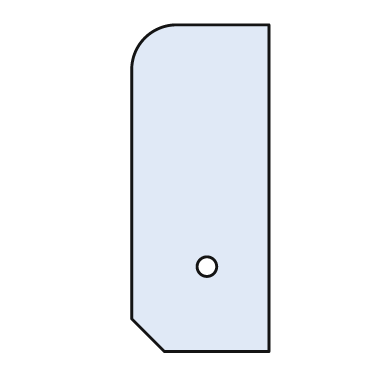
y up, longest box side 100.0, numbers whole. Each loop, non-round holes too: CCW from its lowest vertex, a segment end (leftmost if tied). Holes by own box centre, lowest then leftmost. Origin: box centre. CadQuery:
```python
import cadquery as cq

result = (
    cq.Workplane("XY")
    .moveTo(-11.0, -50.0)
    .lineTo(21.0, -50.0)
    .lineTo(21.0, 50.0)
    .lineTo(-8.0, 50.0)
    .threePointArc((-17.0, 46.0), (-21.0, 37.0))
    .lineTo(-21.0, -40.0)
    .close()
    .moveTo(2.0, -24.0)
    .circle(3.0)
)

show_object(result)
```